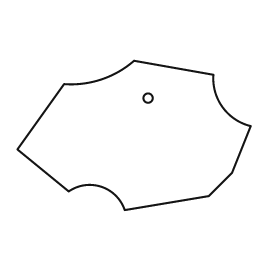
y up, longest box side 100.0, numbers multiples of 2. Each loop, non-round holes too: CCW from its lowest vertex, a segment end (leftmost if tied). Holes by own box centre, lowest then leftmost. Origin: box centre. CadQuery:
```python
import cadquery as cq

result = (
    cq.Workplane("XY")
    .moveTo(-4.0, -32.0)
    .lineTo(32.0, -26.0)
    .lineTo(42.0, -16.0)
    .lineTo(50.0, 4.0)
    .threePointArc((38.0, 12.0), (34.0, 26.0))
    .lineTo(0.0, 32.0)
    .threePointArc((-14.0, 24.0), (-30.0, 22.0))
    .lineTo(-50.0, -6.0)
    .lineTo(-28.0, -24.0)
    .threePointArc((-14.0, -22.0), (-4.0, -32.0))
    .close()
    .moveTo(6.0, 16.0)
    .circle(2.0)
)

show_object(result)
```